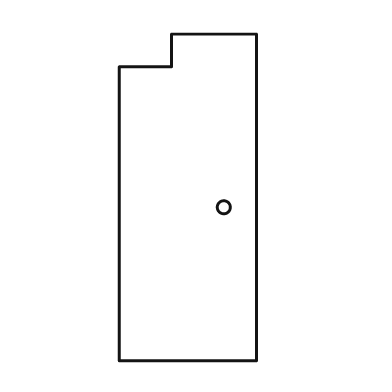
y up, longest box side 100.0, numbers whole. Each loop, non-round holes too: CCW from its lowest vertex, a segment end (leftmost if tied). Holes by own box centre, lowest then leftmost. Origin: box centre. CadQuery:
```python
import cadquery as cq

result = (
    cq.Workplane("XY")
    .moveTo(-21.0, -50.0)
    .lineTo(21.0, -50.0)
    .lineTo(21.0, 50.0)
    .lineTo(-5.0, 50.0)
    .lineTo(-5.0, 40.0)
    .lineTo(-21.0, 40.0)
    .close()
    .moveTo(11.0, -3.0)
    .circle(2.0)
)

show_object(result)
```